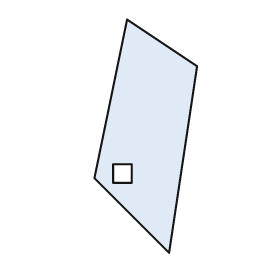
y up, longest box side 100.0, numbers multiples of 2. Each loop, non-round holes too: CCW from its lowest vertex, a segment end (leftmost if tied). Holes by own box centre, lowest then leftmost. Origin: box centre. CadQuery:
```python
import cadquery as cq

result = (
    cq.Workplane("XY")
    .moveTo(10.0, -50.0)
    .lineTo(22.0, 30.0)
    .lineTo(-8.0, 50.0)
    .lineTo(-22.0, -18.0)
    .close()
    .moveTo(-14.0, -20.0)
    .lineTo(-6.0, -20.0)
    .lineTo(-6.0, -12.0)
    .lineTo(-14.0, -12.0)
    .close()
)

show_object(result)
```